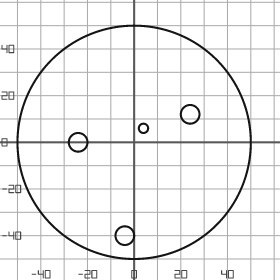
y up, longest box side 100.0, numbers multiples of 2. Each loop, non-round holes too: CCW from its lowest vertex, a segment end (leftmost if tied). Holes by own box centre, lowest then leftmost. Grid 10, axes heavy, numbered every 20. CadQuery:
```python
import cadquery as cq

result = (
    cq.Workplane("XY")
    .moveTo(0.0, 0.0)
    .circle(50.0)
    .moveTo(-4.0, -40.0)
    .circle(4.0)
    .moveTo(-24.0, 0.0)
    .circle(4.0)
    .moveTo(4.0, 6.0)
    .circle(2.0)
    .moveTo(24.0, 12.0)
    .circle(4.0)
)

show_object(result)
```